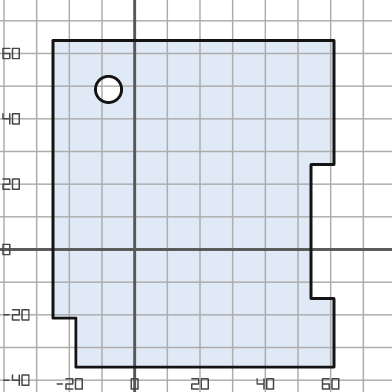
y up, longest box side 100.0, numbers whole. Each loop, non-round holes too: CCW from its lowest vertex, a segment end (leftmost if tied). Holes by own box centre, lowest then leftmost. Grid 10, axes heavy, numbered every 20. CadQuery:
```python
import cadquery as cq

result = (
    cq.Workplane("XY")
    .moveTo(-18.0, -36.0)
    .lineTo(61.0, -36.0)
    .lineTo(61.0, -15.0)
    .lineTo(54.0, -15.0)
    .lineTo(54.0, 26.0)
    .lineTo(61.0, 26.0)
    .lineTo(61.0, 64.0)
    .lineTo(-25.0, 64.0)
    .lineTo(-25.0, -21.0)
    .lineTo(-18.0, -21.0)
    .close()
    .moveTo(-8.0, 49.0)
    .circle(4.0)
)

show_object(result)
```